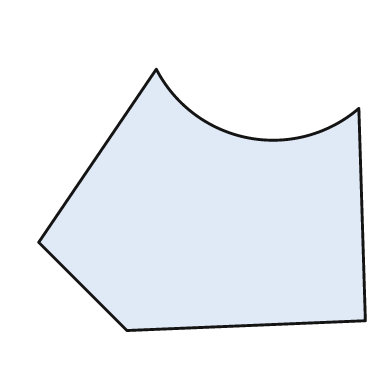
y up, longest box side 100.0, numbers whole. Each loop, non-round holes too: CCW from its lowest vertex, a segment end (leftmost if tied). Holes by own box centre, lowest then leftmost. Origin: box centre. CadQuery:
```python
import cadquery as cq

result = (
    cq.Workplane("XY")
    .moveTo(-23.0, -40.0)
    .lineTo(50.0, -37.0)
    .lineTo(48.0, 28.0)
    .threePointArc((14.0, 19.0), (-14.0, 40.0))
    .lineTo(-50.0, -13.0)
    .close()
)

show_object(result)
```